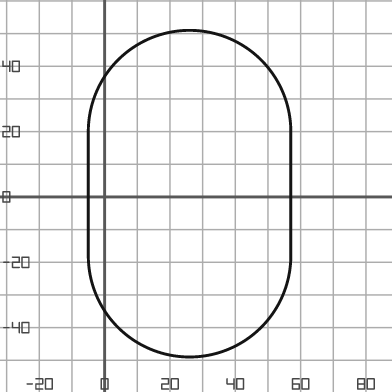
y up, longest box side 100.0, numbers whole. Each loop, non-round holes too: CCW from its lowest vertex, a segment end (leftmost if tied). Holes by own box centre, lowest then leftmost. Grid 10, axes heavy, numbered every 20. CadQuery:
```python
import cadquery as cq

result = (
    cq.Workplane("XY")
    .moveTo(-5.0, -18.0)
    .threePointArc((26.0, -49.0), (57.0, -18.0))
    .lineTo(57.0, 20.0)
    .threePointArc((26.0, 51.0), (-5.0, 20.0))
    .close()
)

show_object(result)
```